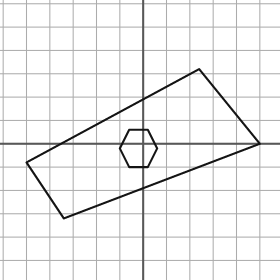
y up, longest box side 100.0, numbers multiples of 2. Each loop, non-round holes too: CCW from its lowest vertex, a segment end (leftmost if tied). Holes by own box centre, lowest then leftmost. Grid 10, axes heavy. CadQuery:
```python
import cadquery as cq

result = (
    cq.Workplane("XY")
    .moveTo(-34.0, -32.0)
    .lineTo(50.0, 0.0)
    .lineTo(24.0, 32.0)
    .lineTo(-50.0, -8.0)
    .close()
    .moveTo(-6.0, -10.0)
    .lineTo(2.0, -10.0)
    .lineTo(6.0, -2.0)
    .lineTo(2.0, 6.0)
    .lineTo(-6.0, 6.0)
    .lineTo(-10.0, -2.0)
    .close()
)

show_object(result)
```